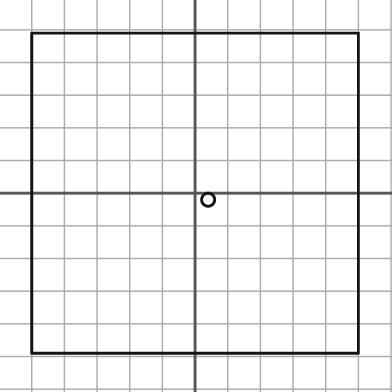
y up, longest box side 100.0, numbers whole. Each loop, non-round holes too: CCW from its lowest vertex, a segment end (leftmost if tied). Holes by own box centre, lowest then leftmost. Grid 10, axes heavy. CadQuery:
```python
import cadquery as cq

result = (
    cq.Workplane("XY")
    .moveTo(-50.0, -49.0)
    .lineTo(50.0, -49.0)
    .lineTo(50.0, 49.0)
    .lineTo(-50.0, 49.0)
    .close()
    .moveTo(4.0, -2.0)
    .circle(2.0)
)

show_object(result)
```